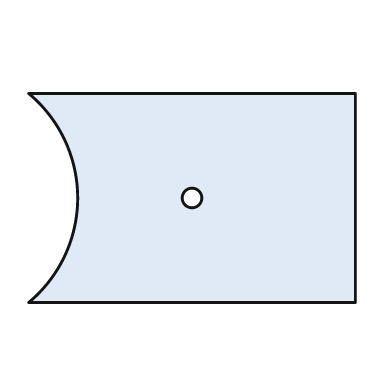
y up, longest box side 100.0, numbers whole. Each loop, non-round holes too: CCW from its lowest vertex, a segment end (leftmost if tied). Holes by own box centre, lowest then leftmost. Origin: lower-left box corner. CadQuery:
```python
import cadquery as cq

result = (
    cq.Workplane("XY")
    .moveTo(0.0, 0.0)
    .lineTo(100.0, 0.0)
    .lineTo(100.0, 64.0)
    .lineTo(0.0, 64.0)
    .threePointArc((15.0, 32.0), (0.0, 0.0))
    .close()
    .moveTo(50.0, 32.0)
    .circle(3.0)
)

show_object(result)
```